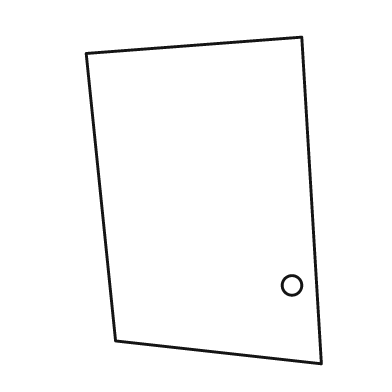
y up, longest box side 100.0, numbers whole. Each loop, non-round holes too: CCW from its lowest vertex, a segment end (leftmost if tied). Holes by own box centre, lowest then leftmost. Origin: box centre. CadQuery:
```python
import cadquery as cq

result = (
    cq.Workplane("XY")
    .moveTo(36.0, -50.0)
    .lineTo(30.0, 50.0)
    .lineTo(-36.0, 45.0)
    .lineTo(-27.0, -43.0)
    .close()
    .moveTo(27.0, -26.0)
    .circle(3.0)
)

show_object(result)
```